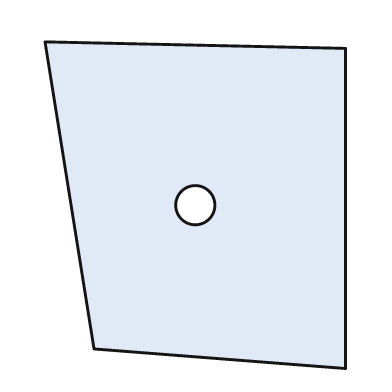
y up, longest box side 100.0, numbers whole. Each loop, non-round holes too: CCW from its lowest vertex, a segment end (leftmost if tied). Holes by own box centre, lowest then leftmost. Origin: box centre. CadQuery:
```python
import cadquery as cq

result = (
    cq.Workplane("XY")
    .moveTo(46.0, -50.0)
    .lineTo(46.0, 48.0)
    .lineTo(-46.0, 50.0)
    .lineTo(-31.0, -44.0)
    .close()
    .moveTo(0.0, 0.0)
    .circle(6.0)
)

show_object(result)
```